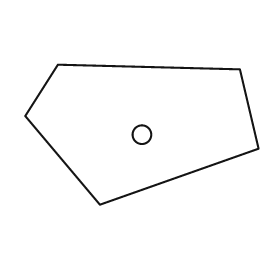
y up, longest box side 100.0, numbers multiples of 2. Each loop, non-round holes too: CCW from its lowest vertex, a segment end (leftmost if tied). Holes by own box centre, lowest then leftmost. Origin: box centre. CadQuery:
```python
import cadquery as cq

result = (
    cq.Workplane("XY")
    .moveTo(-18.0, -30.0)
    .lineTo(50.0, -6.0)
    .lineTo(42.0, 28.0)
    .lineTo(-36.0, 30.0)
    .lineTo(-50.0, 8.0)
    .close()
    .moveTo(0.0, 0.0)
    .circle(4.0)
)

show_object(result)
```